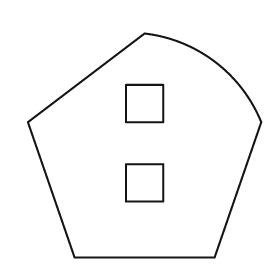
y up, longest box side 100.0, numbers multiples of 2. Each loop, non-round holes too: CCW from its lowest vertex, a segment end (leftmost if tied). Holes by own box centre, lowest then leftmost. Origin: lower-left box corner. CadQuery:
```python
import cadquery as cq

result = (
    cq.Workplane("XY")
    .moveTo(20.0, 0.0)
    .lineTo(80.0, 0.0)
    .lineTo(100.0, 58.0)
    .threePointArc((80.0, 84.0), (50.0, 96.0))
    .lineTo(0.0, 58.0)
    .close()
    .moveTo(42.0, 24.0)
    .lineTo(58.0, 24.0)
    .lineTo(58.0, 40.0)
    .lineTo(42.0, 40.0)
    .close()
    .moveTo(42.0, 58.0)
    .lineTo(58.0, 58.0)
    .lineTo(58.0, 74.0)
    .lineTo(42.0, 74.0)
    .close()
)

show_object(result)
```